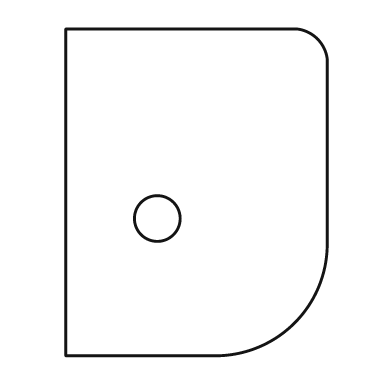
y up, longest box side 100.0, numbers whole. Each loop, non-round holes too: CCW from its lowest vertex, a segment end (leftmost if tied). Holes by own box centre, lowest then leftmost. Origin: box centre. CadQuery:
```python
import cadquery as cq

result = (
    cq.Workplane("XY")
    .moveTo(-40.0, -50.0)
    .lineTo(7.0, -50.0)
    .threePointArc((30.0, -40.0), (40.0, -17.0))
    .lineTo(40.0, 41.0)
    .threePointArc((37.0, 47.0), (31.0, 50.0))
    .lineTo(-40.0, 50.0)
    .close()
    .moveTo(-12.0, -8.0)
    .circle(7.0)
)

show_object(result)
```